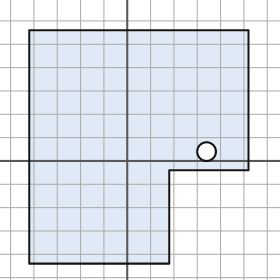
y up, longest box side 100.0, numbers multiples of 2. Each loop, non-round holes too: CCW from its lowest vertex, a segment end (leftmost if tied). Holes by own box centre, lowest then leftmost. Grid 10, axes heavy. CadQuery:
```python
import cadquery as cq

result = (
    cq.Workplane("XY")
    .moveTo(-42.0, -44.0)
    .lineTo(18.0, -44.0)
    .lineTo(18.0, -4.0)
    .lineTo(52.0, -4.0)
    .lineTo(52.0, 56.0)
    .lineTo(-42.0, 56.0)
    .close()
    .moveTo(34.0, 4.0)
    .circle(4.0)
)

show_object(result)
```